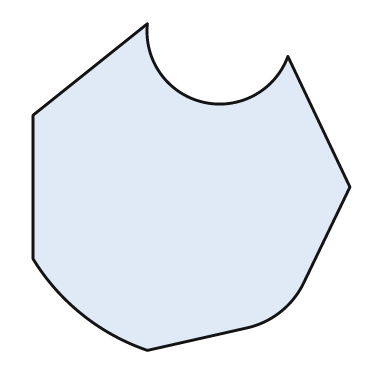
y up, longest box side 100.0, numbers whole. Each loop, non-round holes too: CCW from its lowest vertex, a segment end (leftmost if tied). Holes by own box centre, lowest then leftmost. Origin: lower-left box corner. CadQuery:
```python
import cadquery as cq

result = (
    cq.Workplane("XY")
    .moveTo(35.0, 0.0)
    .lineTo(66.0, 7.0)
    .threePointArc((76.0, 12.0), (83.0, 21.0))
    .lineTo(97.0, 50.0)
    .lineTo(78.0, 90.0)
    .threePointArc((52.0, 76.0), (35.0, 100.0))
    .lineTo(0.0, 72.0)
    .lineTo(0.0, 28.0)
    .threePointArc((15.0, 11.0), (35.0, 0.0))
    .close()
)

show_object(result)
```